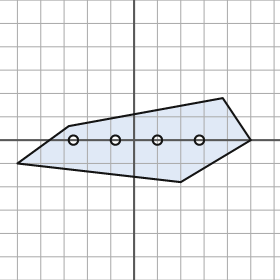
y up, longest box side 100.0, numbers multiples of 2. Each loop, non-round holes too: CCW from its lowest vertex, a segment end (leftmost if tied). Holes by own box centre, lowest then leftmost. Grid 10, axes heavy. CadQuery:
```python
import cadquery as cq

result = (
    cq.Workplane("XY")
    .moveTo(20.0, -18.0)
    .lineTo(50.0, 0.0)
    .lineTo(38.0, 18.0)
    .lineTo(-28.0, 6.0)
    .lineTo(-50.0, -10.0)
    .close()
    .moveTo(-26.0, 0.0)
    .circle(2.0)
    .moveTo(-8.0, 0.0)
    .circle(2.0)
    .moveTo(10.0, 0.0)
    .circle(2.0)
    .moveTo(28.0, 0.0)
    .circle(2.0)
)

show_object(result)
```